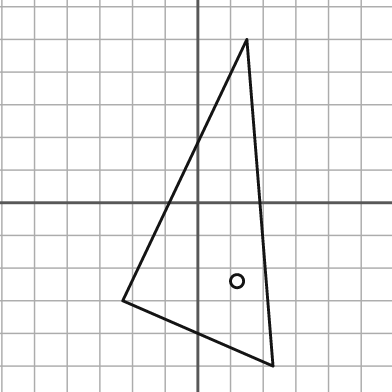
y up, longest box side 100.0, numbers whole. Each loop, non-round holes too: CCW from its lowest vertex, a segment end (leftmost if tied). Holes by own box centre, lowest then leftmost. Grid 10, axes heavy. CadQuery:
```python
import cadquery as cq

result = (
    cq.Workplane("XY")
    .moveTo(23.0, -50.0)
    .lineTo(15.0, 50.0)
    .lineTo(-23.0, -30.0)
    .close()
    .moveTo(12.0, -24.0)
    .circle(2.0)
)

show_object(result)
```